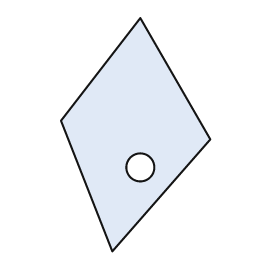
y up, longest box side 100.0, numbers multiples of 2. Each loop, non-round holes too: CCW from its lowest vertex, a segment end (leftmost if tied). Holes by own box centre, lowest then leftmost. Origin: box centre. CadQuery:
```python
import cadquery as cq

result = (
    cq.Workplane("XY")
    .moveTo(-10.0, -50.0)
    .lineTo(32.0, -2.0)
    .lineTo(2.0, 50.0)
    .lineTo(-32.0, 6.0)
    .close()
    .moveTo(2.0, -14.0)
    .circle(6.0)
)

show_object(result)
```